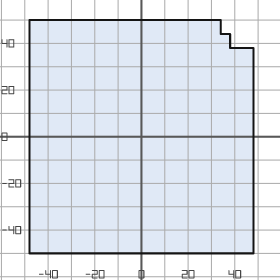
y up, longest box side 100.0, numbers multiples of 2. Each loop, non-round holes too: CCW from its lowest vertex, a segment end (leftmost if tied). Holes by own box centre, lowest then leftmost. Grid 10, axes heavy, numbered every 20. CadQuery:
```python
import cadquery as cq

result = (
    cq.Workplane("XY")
    .moveTo(-48.0, -50.0)
    .lineTo(48.0, -50.0)
    .lineTo(48.0, 38.0)
    .lineTo(38.0, 38.0)
    .lineTo(38.0, 44.0)
    .lineTo(34.0, 44.0)
    .lineTo(34.0, 50.0)
    .lineTo(-48.0, 50.0)
    .close()
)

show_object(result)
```